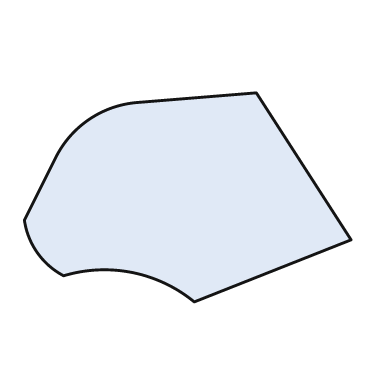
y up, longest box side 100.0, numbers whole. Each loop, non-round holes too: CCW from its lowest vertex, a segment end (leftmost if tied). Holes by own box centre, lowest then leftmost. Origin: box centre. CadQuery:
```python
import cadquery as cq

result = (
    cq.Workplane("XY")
    .moveTo(2.0, -32.0)
    .lineTo(50.0, -13.0)
    .lineTo(21.0, 32.0)
    .lineTo(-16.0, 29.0)
    .threePointArc((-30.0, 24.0), (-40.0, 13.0))
    .lineTo(-50.0, -7.0)
    .threePointArc((-46.0, -17.0), (-38.0, -24.0))
    .threePointArc((-17.0, -23.0), (2.0, -32.0))
    .close()
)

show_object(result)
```